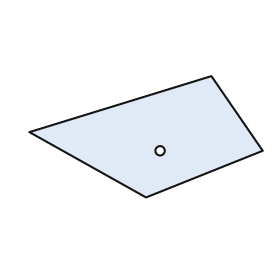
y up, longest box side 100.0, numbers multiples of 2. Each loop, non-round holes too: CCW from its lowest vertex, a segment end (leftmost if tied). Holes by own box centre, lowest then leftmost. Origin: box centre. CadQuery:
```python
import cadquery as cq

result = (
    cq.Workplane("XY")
    .moveTo(0.0, -26.0)
    .lineTo(50.0, -6.0)
    .lineTo(28.0, 26.0)
    .lineTo(-50.0, 2.0)
    .close()
    .moveTo(6.0, -6.0)
    .circle(2.0)
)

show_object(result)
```